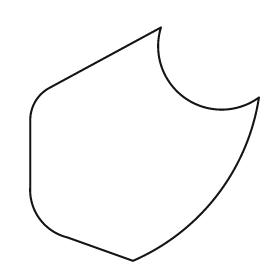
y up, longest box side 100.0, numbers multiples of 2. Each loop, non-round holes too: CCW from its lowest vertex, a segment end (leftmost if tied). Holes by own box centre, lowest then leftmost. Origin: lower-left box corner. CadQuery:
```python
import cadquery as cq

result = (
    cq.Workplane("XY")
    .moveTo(44.0, 0.0)
    .threePointArc((80.0, 28.0), (98.0, 70.0))
    .threePointArc((66.0, 70.0), (56.0, 100.0))
    .lineTo(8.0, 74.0)
    .threePointArc((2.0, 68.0), (0.0, 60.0))
    .lineTo(0.0, 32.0)
    .threePointArc((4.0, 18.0), (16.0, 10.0))
    .close()
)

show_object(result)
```